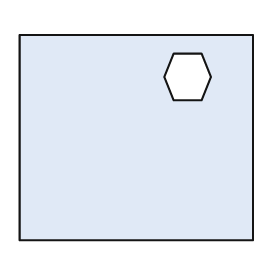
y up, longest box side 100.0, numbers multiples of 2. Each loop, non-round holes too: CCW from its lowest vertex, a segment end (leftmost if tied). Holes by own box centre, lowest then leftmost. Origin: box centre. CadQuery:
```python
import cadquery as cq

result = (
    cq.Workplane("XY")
    .moveTo(-50.0, -44.0)
    .lineTo(50.0, -44.0)
    .lineTo(50.0, 44.0)
    .lineTo(-50.0, 44.0)
    .close()
    .moveTo(16.0, 16.0)
    .lineTo(28.0, 16.0)
    .lineTo(32.0, 26.0)
    .lineTo(28.0, 36.0)
    .lineTo(16.0, 36.0)
    .lineTo(12.0, 26.0)
    .close()
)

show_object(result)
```